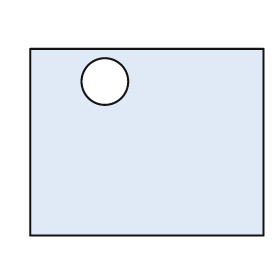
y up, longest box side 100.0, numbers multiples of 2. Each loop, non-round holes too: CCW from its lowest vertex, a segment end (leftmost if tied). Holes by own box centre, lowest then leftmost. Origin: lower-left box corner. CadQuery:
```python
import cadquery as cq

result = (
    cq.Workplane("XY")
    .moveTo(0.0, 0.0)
    .lineTo(100.0, 0.0)
    .lineTo(100.0, 80.0)
    .lineTo(0.0, 80.0)
    .close()
    .moveTo(32.0, 66.0)
    .circle(10.0)
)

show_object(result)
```